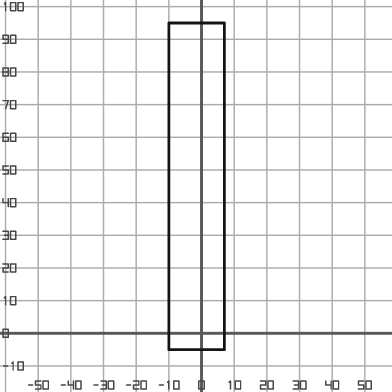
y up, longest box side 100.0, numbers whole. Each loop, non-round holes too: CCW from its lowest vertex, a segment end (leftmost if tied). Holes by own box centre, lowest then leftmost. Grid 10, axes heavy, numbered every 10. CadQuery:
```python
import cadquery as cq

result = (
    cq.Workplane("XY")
    .moveTo(-10.0, -5.0)
    .lineTo(7.0, -5.0)
    .lineTo(7.0, 95.0)
    .lineTo(-10.0, 95.0)
    .close()
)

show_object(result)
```